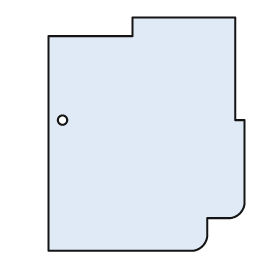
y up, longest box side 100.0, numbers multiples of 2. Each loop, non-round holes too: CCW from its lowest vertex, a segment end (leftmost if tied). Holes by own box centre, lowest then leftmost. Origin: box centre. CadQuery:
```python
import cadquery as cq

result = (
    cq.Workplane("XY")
    .moveTo(-42.0, -50.0)
    .lineTo(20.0, -50.0)
    .threePointArc((24.0, -48.0), (26.0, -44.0))
    .lineTo(26.0, -36.0)
    .lineTo(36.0, -36.0)
    .threePointArc((40.0, -34.0), (42.0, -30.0))
    .lineTo(42.0, 6.0)
    .lineTo(38.0, 6.0)
    .lineTo(38.0, 50.0)
    .lineTo(-6.0, 50.0)
    .lineTo(-6.0, 42.0)
    .lineTo(-42.0, 42.0)
    .close()
    .moveTo(-36.0, 6.0)
    .circle(2.0)
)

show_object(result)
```